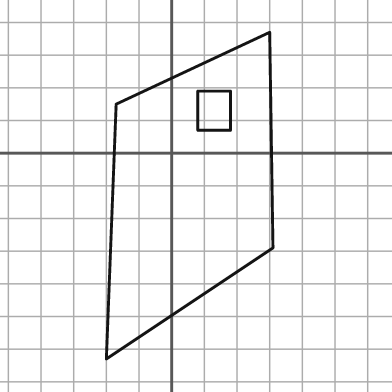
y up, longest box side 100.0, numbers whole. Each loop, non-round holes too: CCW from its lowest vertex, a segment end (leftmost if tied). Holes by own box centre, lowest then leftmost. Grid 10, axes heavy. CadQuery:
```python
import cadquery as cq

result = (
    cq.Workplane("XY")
    .moveTo(-20.0, -63.0)
    .lineTo(31.0, -29.0)
    .lineTo(30.0, 37.0)
    .lineTo(-17.0, 15.0)
    .close()
    .moveTo(8.0, 7.0)
    .lineTo(18.0, 7.0)
    .lineTo(18.0, 19.0)
    .lineTo(8.0, 19.0)
    .close()
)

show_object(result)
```